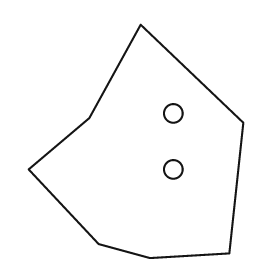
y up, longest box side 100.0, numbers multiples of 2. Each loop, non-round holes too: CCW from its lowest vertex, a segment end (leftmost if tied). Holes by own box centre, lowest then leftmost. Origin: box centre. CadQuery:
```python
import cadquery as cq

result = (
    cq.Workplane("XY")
    .moveTo(6.0, -50.0)
    .lineTo(40.0, -48.0)
    .lineTo(46.0, 8.0)
    .lineTo(2.0, 50.0)
    .lineTo(-20.0, 10.0)
    .lineTo(-46.0, -12.0)
    .lineTo(-16.0, -44.0)
    .close()
    .moveTo(16.0, -12.0)
    .circle(4.0)
    .moveTo(16.0, 12.0)
    .circle(4.0)
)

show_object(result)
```